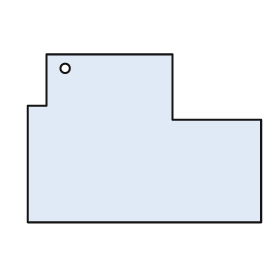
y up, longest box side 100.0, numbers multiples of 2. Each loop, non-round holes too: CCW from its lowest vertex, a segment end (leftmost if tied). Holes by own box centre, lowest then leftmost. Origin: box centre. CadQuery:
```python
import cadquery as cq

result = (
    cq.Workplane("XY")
    .moveTo(-50.0, -36.0)
    .lineTo(50.0, -36.0)
    .lineTo(50.0, 8.0)
    .lineTo(12.0, 8.0)
    .lineTo(12.0, 36.0)
    .lineTo(-42.0, 36.0)
    .lineTo(-42.0, 14.0)
    .lineTo(-50.0, 14.0)
    .close()
    .moveTo(-34.0, 30.0)
    .circle(2.0)
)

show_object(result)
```